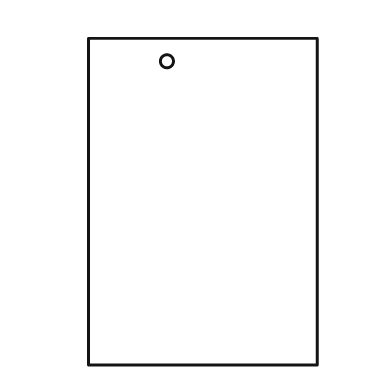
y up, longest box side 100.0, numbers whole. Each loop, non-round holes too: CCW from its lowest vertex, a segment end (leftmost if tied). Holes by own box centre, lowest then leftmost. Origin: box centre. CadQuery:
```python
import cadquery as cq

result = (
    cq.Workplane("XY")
    .moveTo(-35.0, -50.0)
    .lineTo(35.0, -50.0)
    .lineTo(35.0, 50.0)
    .lineTo(-35.0, 50.0)
    .close()
    .moveTo(-11.0, 43.0)
    .circle(2.0)
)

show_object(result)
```